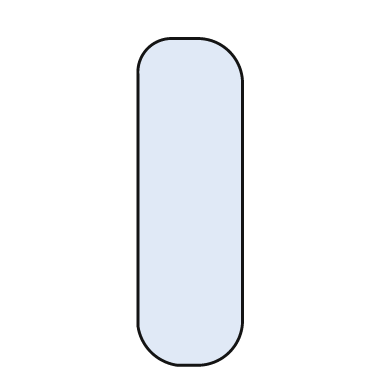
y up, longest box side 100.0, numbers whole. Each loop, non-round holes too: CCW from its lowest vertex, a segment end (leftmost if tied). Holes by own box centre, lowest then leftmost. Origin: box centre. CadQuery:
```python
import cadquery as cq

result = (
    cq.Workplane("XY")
    .moveTo(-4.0, -50.0)
    .lineTo(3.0, -50.0)
    .threePointArc((12.0, -46.0), (16.0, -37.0))
    .lineTo(16.0, 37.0)
    .threePointArc((12.0, 46.0), (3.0, 50.0))
    .lineTo(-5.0, 50.0)
    .threePointArc((-13.0, 47.0), (-16.0, 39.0))
    .lineTo(-16.0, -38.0)
    .threePointArc((-12.0, -46.0), (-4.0, -50.0))
    .close()
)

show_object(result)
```